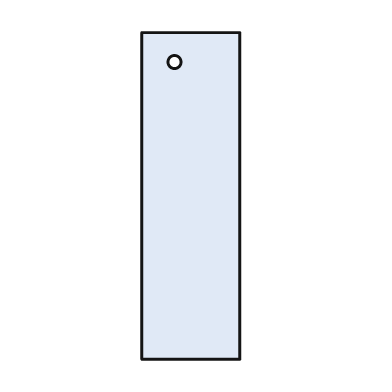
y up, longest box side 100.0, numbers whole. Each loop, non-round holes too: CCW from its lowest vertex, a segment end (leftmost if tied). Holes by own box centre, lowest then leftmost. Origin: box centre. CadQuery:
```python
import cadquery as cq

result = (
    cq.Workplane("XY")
    .moveTo(-15.0, -50.0)
    .lineTo(15.0, -50.0)
    .lineTo(15.0, 50.0)
    .lineTo(-15.0, 50.0)
    .close()
    .moveTo(-5.0, 41.0)
    .circle(2.0)
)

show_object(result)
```